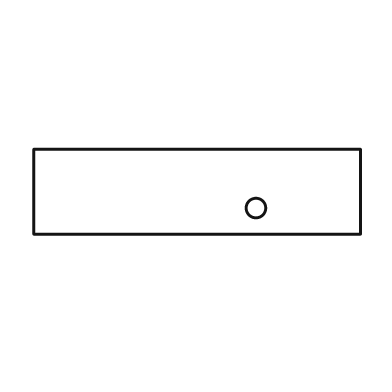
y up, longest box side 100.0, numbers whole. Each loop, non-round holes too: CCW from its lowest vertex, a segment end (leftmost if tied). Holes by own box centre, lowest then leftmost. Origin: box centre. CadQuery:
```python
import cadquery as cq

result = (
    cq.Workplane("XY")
    .moveTo(-50.0, -13.0)
    .lineTo(50.0, -13.0)
    .lineTo(50.0, 13.0)
    .lineTo(-50.0, 13.0)
    .close()
    .moveTo(18.0, -5.0)
    .circle(3.0)
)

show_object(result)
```